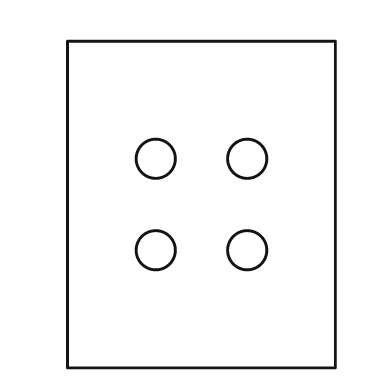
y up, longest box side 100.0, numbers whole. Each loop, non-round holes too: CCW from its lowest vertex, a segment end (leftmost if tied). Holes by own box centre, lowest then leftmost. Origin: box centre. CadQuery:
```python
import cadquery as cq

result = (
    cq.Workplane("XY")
    .moveTo(-41.0, -50.0)
    .lineTo(41.0, -50.0)
    .lineTo(41.0, 50.0)
    .lineTo(-41.0, 50.0)
    .close()
    .moveTo(-14.0, -14.0)
    .circle(6.0)
    .moveTo(14.0, -14.0)
    .circle(6.0)
    .moveTo(-14.0, 14.0)
    .circle(6.0)
    .moveTo(14.0, 14.0)
    .circle(6.0)
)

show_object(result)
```